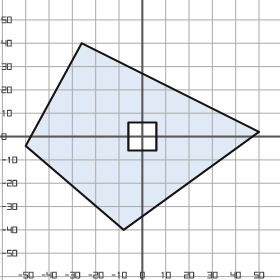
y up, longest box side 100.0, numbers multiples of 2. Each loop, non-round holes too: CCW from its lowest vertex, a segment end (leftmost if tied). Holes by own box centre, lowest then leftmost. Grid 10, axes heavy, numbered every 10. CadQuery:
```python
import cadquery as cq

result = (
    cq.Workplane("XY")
    .moveTo(-8.0, -40.0)
    .lineTo(50.0, 2.0)
    .lineTo(-26.0, 40.0)
    .lineTo(-50.0, -4.0)
    .close()
    .moveTo(-6.0, -6.0)
    .lineTo(6.0, -6.0)
    .lineTo(6.0, 6.0)
    .lineTo(-6.0, 6.0)
    .close()
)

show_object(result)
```